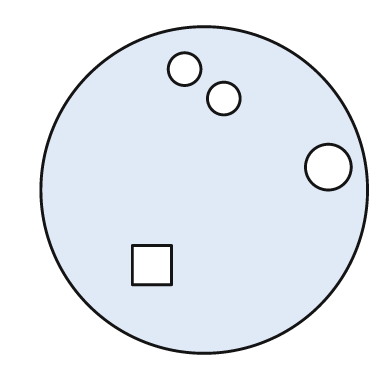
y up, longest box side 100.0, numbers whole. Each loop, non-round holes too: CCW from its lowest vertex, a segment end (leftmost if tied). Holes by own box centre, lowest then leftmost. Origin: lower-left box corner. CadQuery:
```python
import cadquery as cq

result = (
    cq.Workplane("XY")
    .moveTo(50.0, 50.0)
    .circle(50.0)
    .moveTo(28.0, 21.0)
    .lineTo(40.0, 21.0)
    .lineTo(40.0, 33.0)
    .lineTo(28.0, 33.0)
    .close()
    .moveTo(88.0, 57.0)
    .circle(7.0)
    .moveTo(56.0, 78.0)
    .circle(5.0)
    .moveTo(44.0, 87.0)
    .circle(5.0)
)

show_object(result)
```